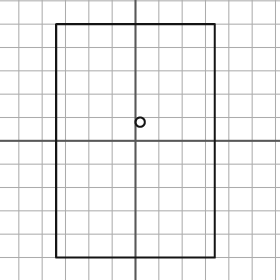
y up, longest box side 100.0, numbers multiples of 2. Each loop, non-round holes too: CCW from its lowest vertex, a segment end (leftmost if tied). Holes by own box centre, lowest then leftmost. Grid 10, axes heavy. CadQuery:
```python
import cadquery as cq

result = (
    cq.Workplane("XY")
    .moveTo(-34.0, -50.0)
    .lineTo(34.0, -50.0)
    .lineTo(34.0, 50.0)
    .lineTo(-34.0, 50.0)
    .close()
    .moveTo(2.0, 8.0)
    .circle(2.0)
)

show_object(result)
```